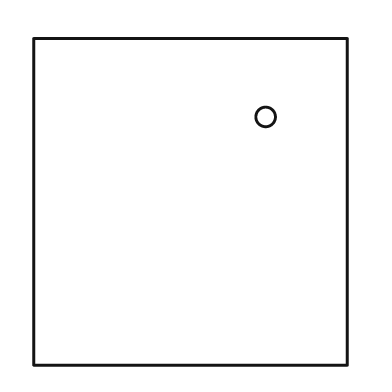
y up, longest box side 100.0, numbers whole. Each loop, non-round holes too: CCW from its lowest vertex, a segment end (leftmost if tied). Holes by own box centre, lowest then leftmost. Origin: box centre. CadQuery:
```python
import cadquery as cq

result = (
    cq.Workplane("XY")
    .moveTo(-48.0, -50.0)
    .lineTo(48.0, -50.0)
    .lineTo(48.0, 50.0)
    .lineTo(-48.0, 50.0)
    .close()
    .moveTo(23.0, 26.0)
    .circle(3.0)
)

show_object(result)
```